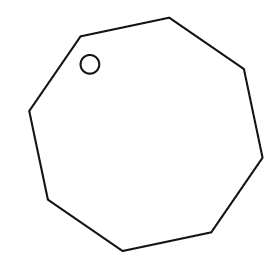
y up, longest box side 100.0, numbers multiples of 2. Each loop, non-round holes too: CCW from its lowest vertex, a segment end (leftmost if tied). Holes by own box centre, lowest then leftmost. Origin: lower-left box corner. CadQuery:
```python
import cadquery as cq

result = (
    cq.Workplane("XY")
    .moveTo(40.0, 0.0)
    .lineTo(78.0, 8.0)
    .lineTo(100.0, 40.0)
    .lineTo(92.0, 78.0)
    .lineTo(60.0, 100.0)
    .lineTo(22.0, 92.0)
    .lineTo(0.0, 60.0)
    .lineTo(8.0, 22.0)
    .close()
    .moveTo(26.0, 80.0)
    .circle(4.0)
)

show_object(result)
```